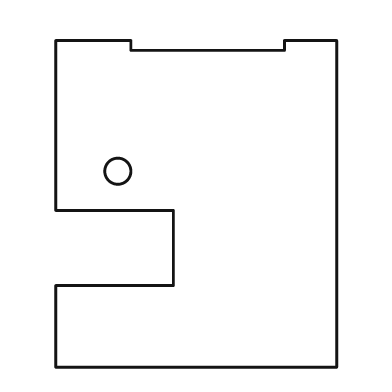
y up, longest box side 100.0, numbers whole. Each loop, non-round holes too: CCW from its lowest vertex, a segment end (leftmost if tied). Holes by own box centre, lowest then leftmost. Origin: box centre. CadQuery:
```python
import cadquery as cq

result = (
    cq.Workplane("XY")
    .moveTo(-43.0, -50.0)
    .lineTo(43.0, -50.0)
    .lineTo(43.0, 50.0)
    .lineTo(27.0, 50.0)
    .lineTo(27.0, 47.0)
    .lineTo(-20.0, 47.0)
    .lineTo(-20.0, 50.0)
    .lineTo(-43.0, 50.0)
    .lineTo(-43.0, -2.0)
    .lineTo(-7.0, -2.0)
    .lineTo(-7.0, -25.0)
    .lineTo(-43.0, -25.0)
    .close()
    .moveTo(-24.0, 10.0)
    .circle(4.0)
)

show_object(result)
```